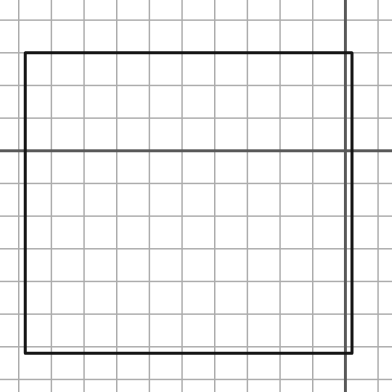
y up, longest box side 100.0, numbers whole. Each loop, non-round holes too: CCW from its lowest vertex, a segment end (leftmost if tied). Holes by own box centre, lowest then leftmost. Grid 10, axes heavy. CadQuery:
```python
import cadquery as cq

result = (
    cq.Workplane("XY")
    .moveTo(-98.0, -62.0)
    .lineTo(2.0, -62.0)
    .lineTo(2.0, 30.0)
    .lineTo(-98.0, 30.0)
    .close()
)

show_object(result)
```